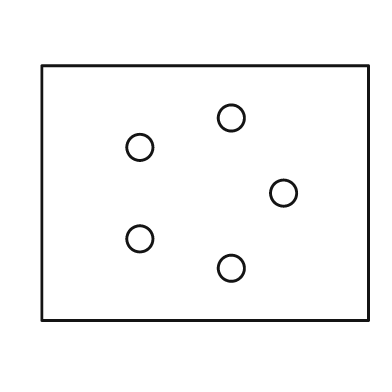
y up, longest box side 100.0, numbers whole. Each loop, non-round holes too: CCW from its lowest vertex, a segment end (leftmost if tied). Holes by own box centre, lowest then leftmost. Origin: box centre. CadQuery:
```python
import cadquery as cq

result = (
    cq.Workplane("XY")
    .moveTo(-50.0, -39.0)
    .lineTo(50.0, -39.0)
    .lineTo(50.0, 39.0)
    .lineTo(-50.0, 39.0)
    .close()
    .moveTo(8.0, -23.0)
    .circle(4.0)
    .moveTo(-20.0, -14.0)
    .circle(4.0)
    .moveTo(24.0, 0.0)
    .circle(4.0)
    .moveTo(-20.0, 14.0)
    .circle(4.0)
    .moveTo(8.0, 23.0)
    .circle(4.0)
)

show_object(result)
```